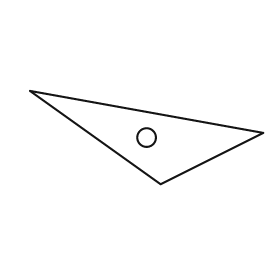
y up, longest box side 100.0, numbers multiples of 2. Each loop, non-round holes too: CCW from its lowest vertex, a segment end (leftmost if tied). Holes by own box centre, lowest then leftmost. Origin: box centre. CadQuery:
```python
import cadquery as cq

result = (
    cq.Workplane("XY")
    .moveTo(6.0, -20.0)
    .lineTo(50.0, 2.0)
    .lineTo(-50.0, 20.0)
    .close()
    .moveTo(0.0, 0.0)
    .circle(4.0)
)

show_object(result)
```